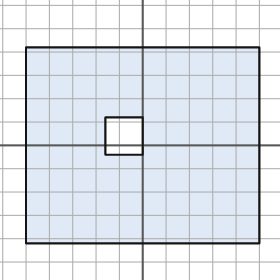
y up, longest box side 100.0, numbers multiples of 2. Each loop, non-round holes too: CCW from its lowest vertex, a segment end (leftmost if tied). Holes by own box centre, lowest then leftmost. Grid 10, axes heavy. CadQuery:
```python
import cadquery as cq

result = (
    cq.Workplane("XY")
    .moveTo(-50.0, -42.0)
    .lineTo(50.0, -42.0)
    .lineTo(50.0, 42.0)
    .lineTo(-50.0, 42.0)
    .close()
    .moveTo(-16.0, -4.0)
    .lineTo(0.0, -4.0)
    .lineTo(0.0, 12.0)
    .lineTo(-16.0, 12.0)
    .close()
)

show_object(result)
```